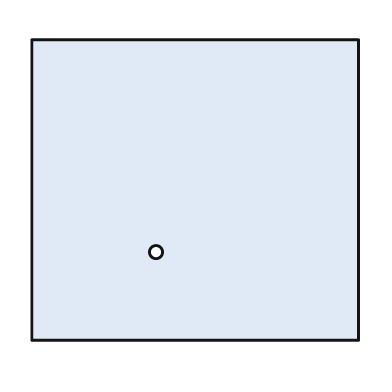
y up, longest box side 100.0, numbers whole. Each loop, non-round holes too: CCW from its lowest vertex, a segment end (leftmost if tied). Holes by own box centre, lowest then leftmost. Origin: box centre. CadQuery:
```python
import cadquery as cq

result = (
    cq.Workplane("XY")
    .moveTo(-50.0, -46.0)
    .lineTo(50.0, -46.0)
    .lineTo(50.0, 46.0)
    .lineTo(-50.0, 46.0)
    .close()
    .moveTo(-12.0, -19.0)
    .circle(2.0)
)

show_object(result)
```